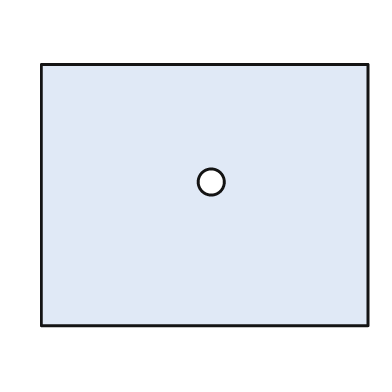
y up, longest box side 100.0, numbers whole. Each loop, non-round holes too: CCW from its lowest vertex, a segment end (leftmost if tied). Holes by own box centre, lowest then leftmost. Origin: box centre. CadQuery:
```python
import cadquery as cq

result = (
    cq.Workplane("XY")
    .moveTo(-50.0, -40.0)
    .lineTo(50.0, -40.0)
    .lineTo(50.0, 40.0)
    .lineTo(-50.0, 40.0)
    .close()
    .moveTo(2.0, 4.0)
    .circle(4.0)
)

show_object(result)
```